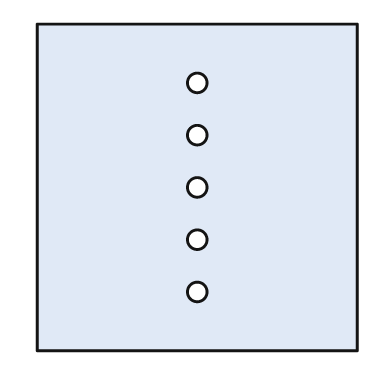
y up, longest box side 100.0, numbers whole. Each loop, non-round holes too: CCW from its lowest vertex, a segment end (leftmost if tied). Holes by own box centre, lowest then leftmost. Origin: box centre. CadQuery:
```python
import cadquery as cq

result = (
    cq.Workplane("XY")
    .moveTo(-49.0, -50.0)
    .lineTo(49.0, -50.0)
    .lineTo(49.0, 50.0)
    .lineTo(-49.0, 50.0)
    .close()
    .moveTo(0.0, -32.0)
    .circle(3.0)
    .moveTo(0.0, -16.0)
    .circle(3.0)
    .moveTo(0.0, 0.0)
    .circle(3.0)
    .moveTo(0.0, 16.0)
    .circle(3.0)
    .moveTo(0.0, 32.0)
    .circle(3.0)
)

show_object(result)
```